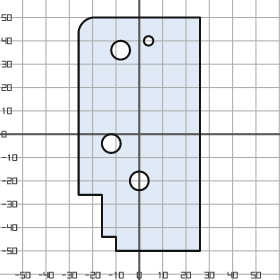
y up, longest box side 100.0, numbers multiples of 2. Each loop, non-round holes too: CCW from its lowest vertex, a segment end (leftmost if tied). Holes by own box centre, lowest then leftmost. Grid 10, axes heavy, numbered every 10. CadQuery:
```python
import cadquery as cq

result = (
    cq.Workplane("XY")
    .moveTo(-10.0, -50.0)
    .lineTo(26.0, -50.0)
    .lineTo(26.0, 50.0)
    .lineTo(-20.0, 50.0)
    .threePointArc((-24.0, 48.0), (-26.0, 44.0))
    .lineTo(-26.0, -26.0)
    .lineTo(-16.0, -26.0)
    .lineTo(-16.0, -44.0)
    .lineTo(-10.0, -44.0)
    .close()
    .moveTo(0.0, -20.0)
    .circle(4.0)
    .moveTo(-12.0, -4.0)
    .circle(4.0)
    .moveTo(-8.0, 36.0)
    .circle(4.0)
    .moveTo(4.0, 40.0)
    .circle(2.0)
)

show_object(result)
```